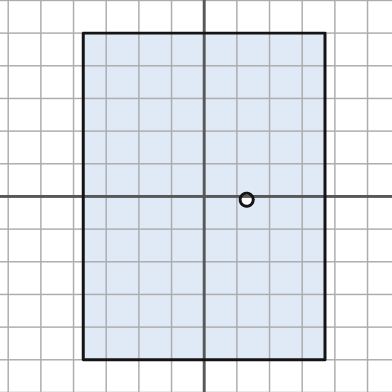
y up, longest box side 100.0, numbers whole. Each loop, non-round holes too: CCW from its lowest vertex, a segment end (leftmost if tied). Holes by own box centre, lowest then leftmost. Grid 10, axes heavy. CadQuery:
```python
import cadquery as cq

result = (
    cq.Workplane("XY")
    .moveTo(-37.0, -50.0)
    .lineTo(37.0, -50.0)
    .lineTo(37.0, 50.0)
    .lineTo(-37.0, 50.0)
    .close()
    .moveTo(13.0, -1.0)
    .circle(2.0)
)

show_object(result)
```